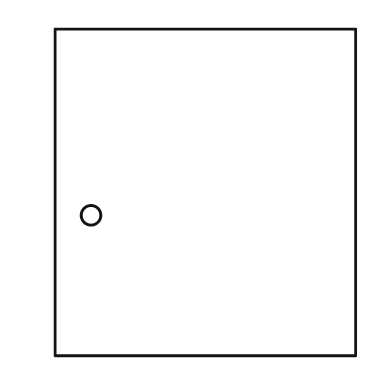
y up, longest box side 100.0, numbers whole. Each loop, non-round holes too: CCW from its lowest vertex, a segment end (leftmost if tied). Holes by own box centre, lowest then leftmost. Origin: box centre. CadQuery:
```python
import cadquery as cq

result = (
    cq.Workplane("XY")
    .moveTo(-46.0, -50.0)
    .lineTo(46.0, -50.0)
    .lineTo(46.0, 50.0)
    .lineTo(-46.0, 50.0)
    .close()
    .moveTo(-35.0, -7.0)
    .circle(3.0)
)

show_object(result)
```